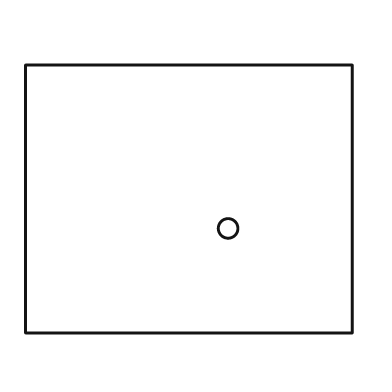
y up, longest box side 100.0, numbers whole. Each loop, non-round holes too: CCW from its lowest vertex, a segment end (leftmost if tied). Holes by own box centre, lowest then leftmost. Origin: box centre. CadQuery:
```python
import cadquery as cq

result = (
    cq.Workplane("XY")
    .moveTo(-50.0, -41.0)
    .lineTo(50.0, -41.0)
    .lineTo(50.0, 41.0)
    .lineTo(-50.0, 41.0)
    .close()
    .moveTo(12.0, -9.0)
    .circle(3.0)
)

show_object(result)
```